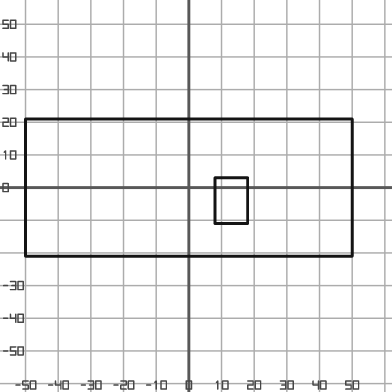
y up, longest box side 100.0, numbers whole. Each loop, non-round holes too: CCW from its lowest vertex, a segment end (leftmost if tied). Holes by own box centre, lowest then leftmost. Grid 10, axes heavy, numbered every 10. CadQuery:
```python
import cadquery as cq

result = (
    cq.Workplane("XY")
    .moveTo(-50.0, -21.0)
    .lineTo(50.0, -21.0)
    .lineTo(50.0, 21.0)
    .lineTo(-50.0, 21.0)
    .close()
    .moveTo(8.0, -11.0)
    .lineTo(18.0, -11.0)
    .lineTo(18.0, 3.0)
    .lineTo(8.0, 3.0)
    .close()
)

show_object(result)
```